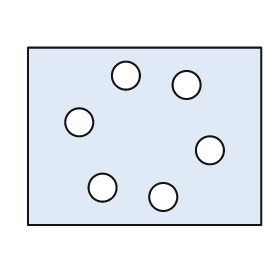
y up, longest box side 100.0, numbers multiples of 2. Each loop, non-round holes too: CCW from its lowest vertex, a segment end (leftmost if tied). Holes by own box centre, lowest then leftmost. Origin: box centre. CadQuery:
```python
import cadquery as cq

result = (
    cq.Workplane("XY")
    .moveTo(-50.0, -38.0)
    .lineTo(50.0, -38.0)
    .lineTo(50.0, 38.0)
    .lineTo(-50.0, 38.0)
    .close()
    .moveTo(8.0, -26.0)
    .circle(6.0)
    .moveTo(-18.0, -22.0)
    .circle(6.0)
    .moveTo(28.0, -6.0)
    .circle(6.0)
    .moveTo(-28.0, 6.0)
    .circle(6.0)
    .moveTo(18.0, 22.0)
    .circle(6.0)
    .moveTo(-8.0, 26.0)
    .circle(6.0)
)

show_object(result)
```